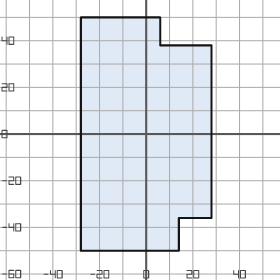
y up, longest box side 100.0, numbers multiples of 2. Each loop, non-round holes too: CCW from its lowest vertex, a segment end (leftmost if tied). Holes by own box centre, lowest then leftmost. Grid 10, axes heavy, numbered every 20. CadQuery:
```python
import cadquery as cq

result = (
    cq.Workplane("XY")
    .moveTo(-28.0, -50.0)
    .lineTo(14.0, -50.0)
    .lineTo(14.0, -36.0)
    .lineTo(28.0, -36.0)
    .lineTo(28.0, 38.0)
    .lineTo(6.0, 38.0)
    .lineTo(6.0, 50.0)
    .lineTo(-28.0, 50.0)
    .close()
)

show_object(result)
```